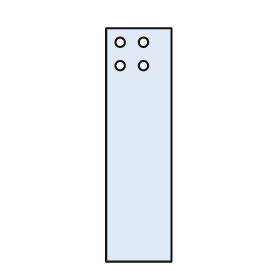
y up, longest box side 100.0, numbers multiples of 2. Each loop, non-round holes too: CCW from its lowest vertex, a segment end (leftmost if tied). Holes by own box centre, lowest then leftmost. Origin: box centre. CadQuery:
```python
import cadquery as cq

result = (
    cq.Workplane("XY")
    .moveTo(-14.0, -50.0)
    .lineTo(14.0, -50.0)
    .lineTo(14.0, 50.0)
    .lineTo(-14.0, 50.0)
    .close()
    .moveTo(-8.0, 34.0)
    .circle(2.0)
    .moveTo(2.0, 34.0)
    .circle(2.0)
    .moveTo(-8.0, 44.0)
    .circle(2.0)
    .moveTo(2.0, 44.0)
    .circle(2.0)
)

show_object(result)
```